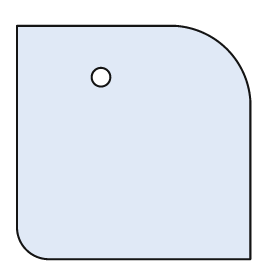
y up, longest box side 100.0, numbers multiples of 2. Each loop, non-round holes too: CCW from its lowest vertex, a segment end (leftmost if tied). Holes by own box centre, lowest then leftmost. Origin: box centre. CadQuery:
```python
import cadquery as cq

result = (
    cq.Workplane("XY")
    .moveTo(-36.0, -50.0)
    .lineTo(50.0, -50.0)
    .lineTo(50.0, 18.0)
    .threePointArc((40.0, 40.0), (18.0, 50.0))
    .lineTo(-50.0, 50.0)
    .lineTo(-50.0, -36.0)
    .threePointArc((-46.0, -46.0), (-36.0, -50.0))
    .close()
    .moveTo(-14.0, 28.0)
    .circle(4.0)
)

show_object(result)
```